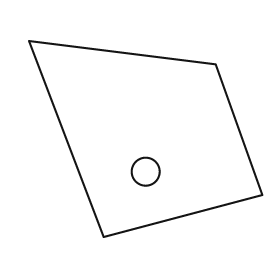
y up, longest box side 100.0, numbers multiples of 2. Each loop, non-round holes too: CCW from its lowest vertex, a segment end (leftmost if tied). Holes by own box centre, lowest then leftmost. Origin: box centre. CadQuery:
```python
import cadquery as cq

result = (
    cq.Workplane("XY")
    .moveTo(-18.0, -42.0)
    .lineTo(50.0, -24.0)
    .lineTo(30.0, 32.0)
    .lineTo(-50.0, 42.0)
    .close()
    .moveTo(0.0, -14.0)
    .circle(6.0)
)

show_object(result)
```